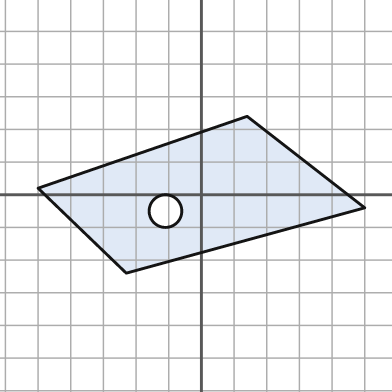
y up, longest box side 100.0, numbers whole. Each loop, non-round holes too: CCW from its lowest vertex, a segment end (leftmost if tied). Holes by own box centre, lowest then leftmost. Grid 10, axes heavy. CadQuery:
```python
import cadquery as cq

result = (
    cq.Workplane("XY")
    .moveTo(-23.0, -24.0)
    .lineTo(50.0, -4.0)
    .lineTo(14.0, 24.0)
    .lineTo(-50.0, 2.0)
    .close()
    .moveTo(-11.0, -5.0)
    .circle(5.0)
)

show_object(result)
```